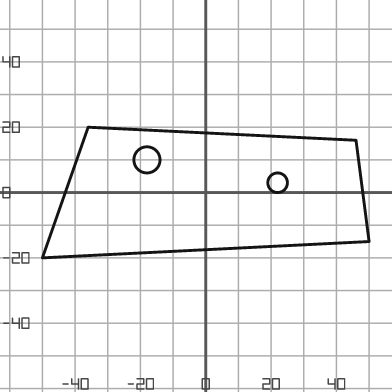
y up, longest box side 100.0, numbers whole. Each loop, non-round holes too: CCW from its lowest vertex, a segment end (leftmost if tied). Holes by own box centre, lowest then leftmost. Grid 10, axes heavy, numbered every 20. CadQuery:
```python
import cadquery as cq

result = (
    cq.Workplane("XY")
    .moveTo(-50.0, -20.0)
    .lineTo(50.0, -15.0)
    .lineTo(46.0, 16.0)
    .lineTo(-36.0, 20.0)
    .close()
    .moveTo(22.0, 3.0)
    .circle(3.0)
    .moveTo(-18.0, 10.0)
    .circle(4.0)
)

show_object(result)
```